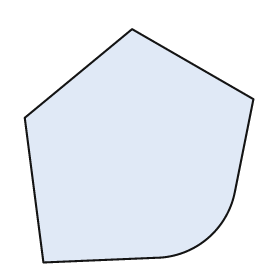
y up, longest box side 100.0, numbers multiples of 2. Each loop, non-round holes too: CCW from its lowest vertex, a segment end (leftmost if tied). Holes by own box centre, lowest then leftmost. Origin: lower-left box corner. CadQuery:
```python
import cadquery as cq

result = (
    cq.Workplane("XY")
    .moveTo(8.0, 0.0)
    .lineTo(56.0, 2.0)
    .threePointArc((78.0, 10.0), (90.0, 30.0))
    .lineTo(98.0, 70.0)
    .lineTo(46.0, 100.0)
    .lineTo(0.0, 62.0)
    .close()
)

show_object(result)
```